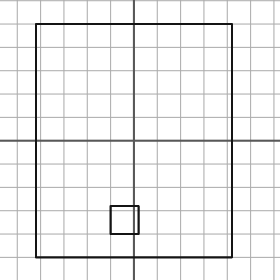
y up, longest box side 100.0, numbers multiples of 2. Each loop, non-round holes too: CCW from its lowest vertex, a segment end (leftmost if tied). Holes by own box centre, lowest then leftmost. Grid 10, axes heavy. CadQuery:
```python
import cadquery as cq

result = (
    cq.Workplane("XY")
    .moveTo(-42.0, -50.0)
    .lineTo(42.0, -50.0)
    .lineTo(42.0, 50.0)
    .lineTo(-42.0, 50.0)
    .close()
    .moveTo(-10.0, -40.0)
    .lineTo(2.0, -40.0)
    .lineTo(2.0, -28.0)
    .lineTo(-10.0, -28.0)
    .close()
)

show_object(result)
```